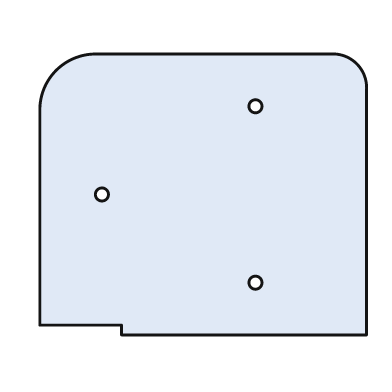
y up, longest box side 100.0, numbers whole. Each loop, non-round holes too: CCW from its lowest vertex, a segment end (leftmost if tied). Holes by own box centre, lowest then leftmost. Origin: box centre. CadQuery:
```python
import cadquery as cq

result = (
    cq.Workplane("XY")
    .moveTo(-25.0, -43.0)
    .lineTo(50.0, -43.0)
    .lineTo(50.0, 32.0)
    .threePointArc((47.0, 40.0), (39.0, 43.0))
    .lineTo(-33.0, 43.0)
    .threePointArc((-45.0, 38.0), (-50.0, 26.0))
    .lineTo(-50.0, -40.0)
    .lineTo(-25.0, -40.0)
    .close()
    .moveTo(16.0, -27.0)
    .circle(2.0)
    .moveTo(-31.0, 0.0)
    .circle(2.0)
    .moveTo(16.0, 27.0)
    .circle(2.0)
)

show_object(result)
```